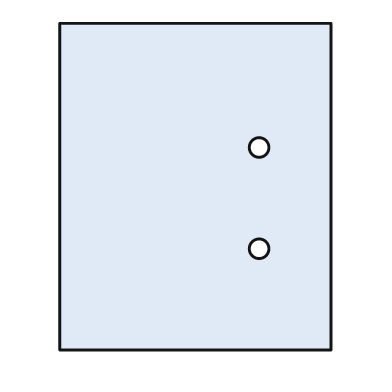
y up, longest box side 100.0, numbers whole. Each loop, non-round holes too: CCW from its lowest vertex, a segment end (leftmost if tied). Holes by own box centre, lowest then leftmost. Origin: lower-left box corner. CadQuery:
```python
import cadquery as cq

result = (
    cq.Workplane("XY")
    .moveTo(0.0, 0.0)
    .lineTo(83.0, 0.0)
    .lineTo(83.0, 100.0)
    .lineTo(0.0, 100.0)
    .close()
    .moveTo(61.0, 31.0)
    .circle(3.0)
    .moveTo(61.0, 62.0)
    .circle(3.0)
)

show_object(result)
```